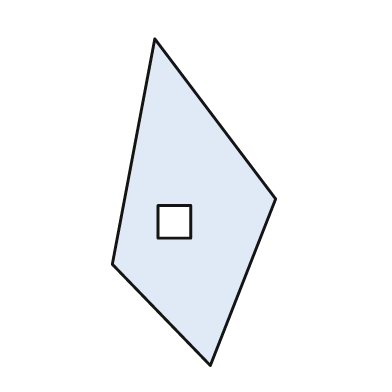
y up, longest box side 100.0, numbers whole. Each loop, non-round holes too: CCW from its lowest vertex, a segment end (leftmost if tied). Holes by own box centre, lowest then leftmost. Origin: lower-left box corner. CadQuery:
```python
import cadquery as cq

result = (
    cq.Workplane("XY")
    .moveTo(30.0, 0.0)
    .lineTo(50.0, 51.0)
    .lineTo(13.0, 100.0)
    .lineTo(0.0, 31.0)
    .close()
    .moveTo(14.0, 39.0)
    .lineTo(24.0, 39.0)
    .lineTo(24.0, 49.0)
    .lineTo(14.0, 49.0)
    .close()
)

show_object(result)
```